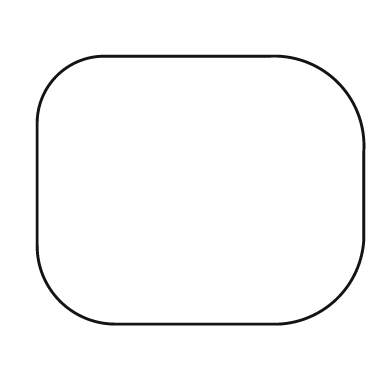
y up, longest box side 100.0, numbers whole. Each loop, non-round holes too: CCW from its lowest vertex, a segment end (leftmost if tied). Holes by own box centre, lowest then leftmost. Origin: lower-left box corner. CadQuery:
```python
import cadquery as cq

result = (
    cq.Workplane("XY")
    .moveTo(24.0, 0.0)
    .lineTo(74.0, 0.0)
    .threePointArc((92.0, 8.0), (100.0, 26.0))
    .lineTo(100.0, 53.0)
    .threePointArc((92.0, 74.0), (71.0, 82.0))
    .lineTo(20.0, 82.0)
    .threePointArc((6.0, 76.0), (0.0, 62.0))
    .lineTo(0.0, 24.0)
    .threePointArc((7.0, 7.0), (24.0, 0.0))
    .close()
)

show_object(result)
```